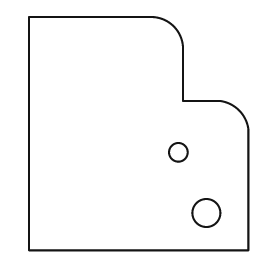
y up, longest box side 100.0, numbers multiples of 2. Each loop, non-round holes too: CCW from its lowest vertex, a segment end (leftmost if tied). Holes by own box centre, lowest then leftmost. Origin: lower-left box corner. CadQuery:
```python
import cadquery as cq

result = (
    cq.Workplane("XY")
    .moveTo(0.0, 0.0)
    .lineTo(94.0, 0.0)
    .lineTo(94.0, 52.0)
    .threePointArc((90.0, 60.0), (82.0, 64.0))
    .lineTo(66.0, 64.0)
    .lineTo(66.0, 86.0)
    .threePointArc((62.0, 96.0), (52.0, 100.0))
    .lineTo(0.0, 100.0)
    .close()
    .moveTo(76.0, 16.0)
    .circle(6.0)
    .moveTo(64.0, 42.0)
    .circle(4.0)
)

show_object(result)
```